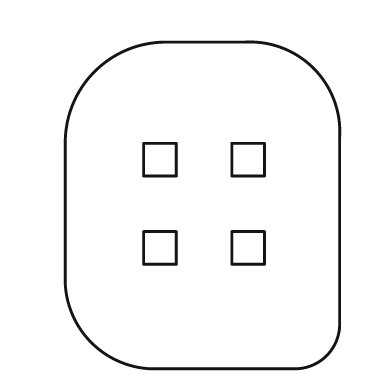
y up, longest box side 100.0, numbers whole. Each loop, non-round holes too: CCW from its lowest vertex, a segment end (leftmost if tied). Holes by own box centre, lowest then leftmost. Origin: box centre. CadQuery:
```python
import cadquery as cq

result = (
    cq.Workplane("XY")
    .moveTo(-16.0, -50.0)
    .lineTo(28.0, -50.0)
    .threePointArc((38.0, -46.0), (42.0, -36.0))
    .lineTo(42.0, 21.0)
    .threePointArc((34.0, 42.0), (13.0, 50.0))
    .lineTo(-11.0, 50.0)
    .threePointArc((-33.0, 41.0), (-42.0, 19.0))
    .lineTo(-42.0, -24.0)
    .threePointArc((-34.0, -42.0), (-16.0, -50.0))
    .close()
    .moveTo(-18.0, -18.0)
    .lineTo(-8.0, -18.0)
    .lineTo(-8.0, -8.0)
    .lineTo(-18.0, -8.0)
    .close()
    .moveTo(9.0, -18.0)
    .lineTo(19.0, -18.0)
    .lineTo(19.0, -8.0)
    .lineTo(9.0, -8.0)
    .close()
    .moveTo(-18.0, 9.0)
    .lineTo(-8.0, 9.0)
    .lineTo(-8.0, 19.0)
    .lineTo(-18.0, 19.0)
    .close()
    .moveTo(9.0, 9.0)
    .lineTo(19.0, 9.0)
    .lineTo(19.0, 19.0)
    .lineTo(9.0, 19.0)
    .close()
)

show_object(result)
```